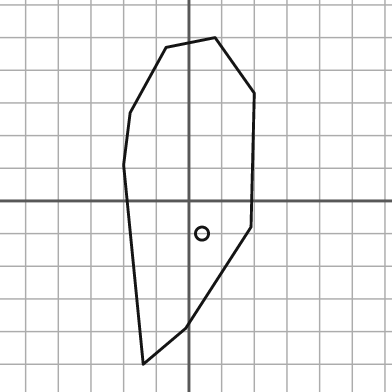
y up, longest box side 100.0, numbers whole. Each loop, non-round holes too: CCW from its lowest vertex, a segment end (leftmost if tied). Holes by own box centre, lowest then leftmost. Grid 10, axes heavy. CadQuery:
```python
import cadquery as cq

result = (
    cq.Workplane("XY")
    .moveTo(-14.0, -50.0)
    .lineTo(-1.0, -39.0)
    .lineTo(19.0, -8.0)
    .lineTo(20.0, 33.0)
    .lineTo(8.0, 50.0)
    .lineTo(-7.0, 47.0)
    .lineTo(-18.0, 27.0)
    .lineTo(-20.0, 11.0)
    .close()
    .moveTo(4.0, -10.0)
    .circle(2.0)
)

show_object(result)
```